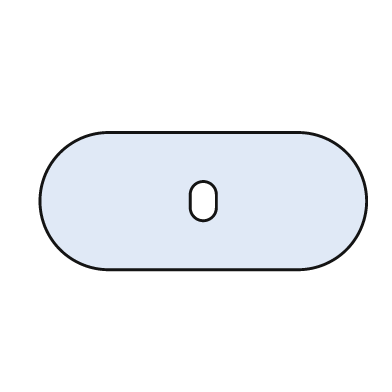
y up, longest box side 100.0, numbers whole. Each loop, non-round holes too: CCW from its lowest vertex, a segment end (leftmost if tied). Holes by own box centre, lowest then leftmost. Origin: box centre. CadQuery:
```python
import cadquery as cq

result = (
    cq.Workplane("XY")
    .moveTo(-29.0, -21.0)
    .lineTo(29.0, -21.0)
    .threePointArc((50.0, 0.0), (29.0, 21.0))
    .lineTo(-29.0, 21.0)
    .threePointArc((-50.0, 0.0), (-29.0, -21.0))
    .close()
    .moveTo(-4.0, -2.0)
    .threePointArc((0.0, -6.0), (4.0, -2.0))
    .lineTo(4.0, 2.0)
    .threePointArc((0.0, 6.0), (-4.0, 2.0))
    .close()
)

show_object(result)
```